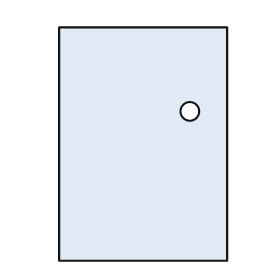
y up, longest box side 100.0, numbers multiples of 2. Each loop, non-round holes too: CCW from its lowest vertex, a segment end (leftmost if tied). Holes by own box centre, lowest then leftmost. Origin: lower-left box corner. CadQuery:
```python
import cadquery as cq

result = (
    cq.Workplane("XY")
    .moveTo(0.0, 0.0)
    .lineTo(72.0, 0.0)
    .lineTo(72.0, 100.0)
    .lineTo(0.0, 100.0)
    .close()
    .moveTo(56.0, 64.0)
    .circle(4.0)
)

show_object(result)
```